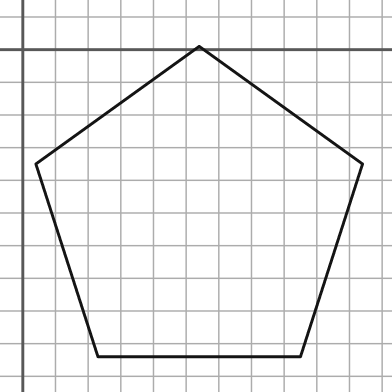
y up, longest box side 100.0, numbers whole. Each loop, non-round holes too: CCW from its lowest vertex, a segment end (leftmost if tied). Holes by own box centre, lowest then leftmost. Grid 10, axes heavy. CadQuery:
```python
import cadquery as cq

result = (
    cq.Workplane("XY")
    .moveTo(23.0, -94.0)
    .lineTo(85.0, -94.0)
    .lineTo(104.0, -35.0)
    .lineTo(54.0, 1.0)
    .lineTo(4.0, -35.0)
    .close()
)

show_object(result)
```